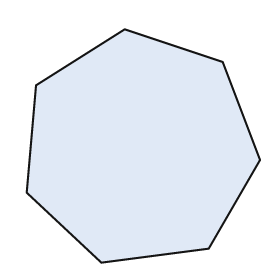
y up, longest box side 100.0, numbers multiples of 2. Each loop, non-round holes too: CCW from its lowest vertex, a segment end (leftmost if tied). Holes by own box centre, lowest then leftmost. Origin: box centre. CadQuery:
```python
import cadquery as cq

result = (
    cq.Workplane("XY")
    .moveTo(-18.0, -50.0)
    .lineTo(28.0, -44.0)
    .lineTo(50.0, -6.0)
    .lineTo(34.0, 36.0)
    .lineTo(-8.0, 50.0)
    .lineTo(-46.0, 26.0)
    .lineTo(-50.0, -20.0)
    .close()
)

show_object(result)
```